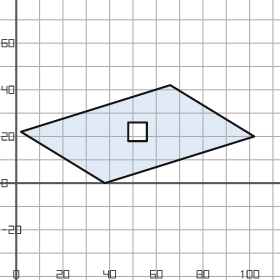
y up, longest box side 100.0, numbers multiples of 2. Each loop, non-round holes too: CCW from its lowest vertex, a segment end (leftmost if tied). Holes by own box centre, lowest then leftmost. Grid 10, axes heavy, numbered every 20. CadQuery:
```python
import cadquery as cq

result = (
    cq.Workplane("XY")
    .moveTo(38.0, 0.0)
    .lineTo(102.0, 20.0)
    .lineTo(66.0, 42.0)
    .lineTo(2.0, 22.0)
    .close()
    .moveTo(48.0, 18.0)
    .lineTo(56.0, 18.0)
    .lineTo(56.0, 26.0)
    .lineTo(48.0, 26.0)
    .close()
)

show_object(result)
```